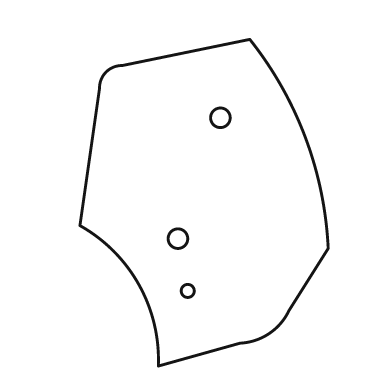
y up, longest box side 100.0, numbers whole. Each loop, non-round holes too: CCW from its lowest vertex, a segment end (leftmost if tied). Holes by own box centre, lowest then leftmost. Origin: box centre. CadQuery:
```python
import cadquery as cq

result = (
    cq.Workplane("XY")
    .moveTo(-14.0, -50.0)
    .lineTo(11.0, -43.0)
    .threePointArc((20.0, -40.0), (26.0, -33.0))
    .lineTo(38.0, -14.0)
    .threePointArc((31.0, 20.0), (14.0, 50.0))
    .lineTo(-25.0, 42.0)
    .threePointArc((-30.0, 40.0), (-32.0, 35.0))
    .lineTo(-38.0, -7.0)
    .threePointArc((-20.0, -25.0), (-14.0, -50.0))
    .close()
    .moveTo(-5.0, -27.0)
    .circle(2.0)
    .moveTo(-8.0, -11.0)
    .circle(3.0)
    .moveTo(5.0, 26.0)
    .circle(3.0)
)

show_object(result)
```